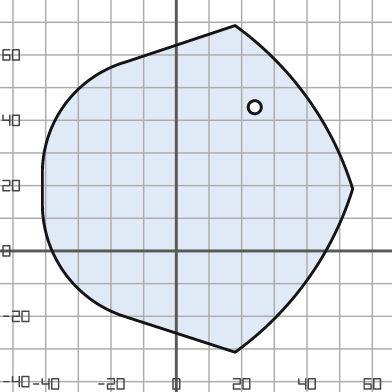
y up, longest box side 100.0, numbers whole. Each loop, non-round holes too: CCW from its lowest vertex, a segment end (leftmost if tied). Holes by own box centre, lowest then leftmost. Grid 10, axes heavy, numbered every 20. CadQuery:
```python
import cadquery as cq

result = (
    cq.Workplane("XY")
    .moveTo(18.0, -31.0)
    .threePointArc((40.0, -9.0), (54.0, 19.0))
    .threePointArc((40.0, 47.0), (18.0, 69.0))
    .lineTo(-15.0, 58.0)
    .threePointArc((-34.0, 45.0), (-41.0, 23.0))
    .lineTo(-41.0, 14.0)
    .threePointArc((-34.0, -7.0), (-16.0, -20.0))
    .close()
    .moveTo(24.0, 44.0)
    .circle(2.0)
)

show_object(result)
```